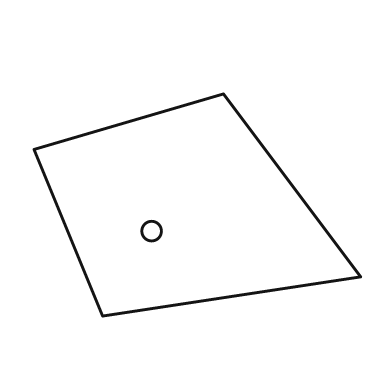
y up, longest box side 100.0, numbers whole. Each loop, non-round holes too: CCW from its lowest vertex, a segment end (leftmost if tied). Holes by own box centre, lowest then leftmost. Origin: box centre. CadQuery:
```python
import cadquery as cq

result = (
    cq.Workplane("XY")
    .moveTo(-29.0, -34.0)
    .lineTo(50.0, -22.0)
    .lineTo(8.0, 34.0)
    .lineTo(-50.0, 17.0)
    .close()
    .moveTo(-14.0, -8.0)
    .circle(3.0)
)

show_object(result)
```